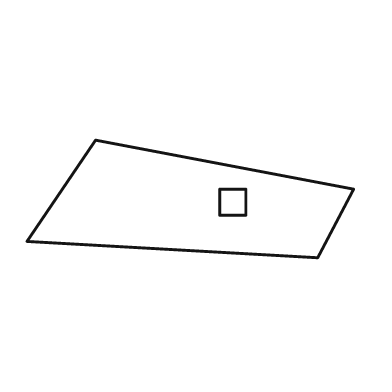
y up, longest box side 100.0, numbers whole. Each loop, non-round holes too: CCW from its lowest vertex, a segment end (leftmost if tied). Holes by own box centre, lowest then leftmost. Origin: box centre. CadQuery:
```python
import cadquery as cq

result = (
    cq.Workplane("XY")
    .moveTo(39.0, -18.0)
    .lineTo(50.0, 3.0)
    .lineTo(-29.0, 18.0)
    .lineTo(-50.0, -13.0)
    .close()
    .moveTo(9.0, -5.0)
    .lineTo(17.0, -5.0)
    .lineTo(17.0, 3.0)
    .lineTo(9.0, 3.0)
    .close()
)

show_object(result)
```